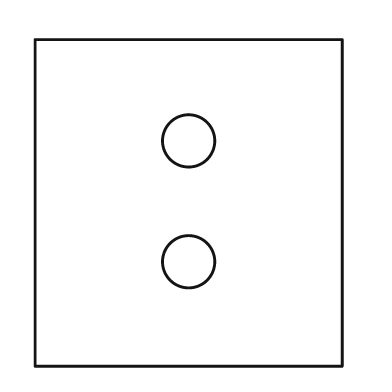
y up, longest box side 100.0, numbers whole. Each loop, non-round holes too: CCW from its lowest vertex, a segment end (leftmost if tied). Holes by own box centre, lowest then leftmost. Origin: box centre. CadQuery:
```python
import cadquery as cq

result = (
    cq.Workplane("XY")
    .moveTo(-47.0, -50.0)
    .lineTo(47.0, -50.0)
    .lineTo(47.0, 50.0)
    .lineTo(-47.0, 50.0)
    .close()
    .moveTo(0.0, -18.0)
    .circle(8.0)
    .moveTo(0.0, 19.0)
    .circle(8.0)
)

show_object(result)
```